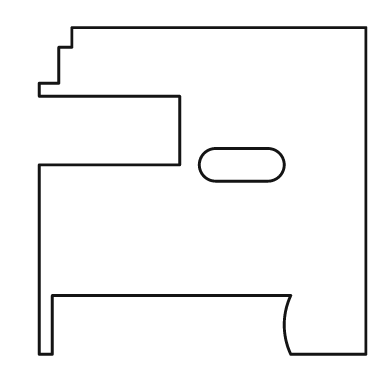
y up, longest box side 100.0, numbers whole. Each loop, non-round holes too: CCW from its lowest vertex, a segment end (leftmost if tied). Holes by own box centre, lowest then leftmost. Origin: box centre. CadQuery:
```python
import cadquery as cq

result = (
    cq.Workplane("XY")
    .moveTo(-50.0, -50.0)
    .lineTo(-46.0, -50.0)
    .lineTo(-46.0, -32.0)
    .lineTo(27.0, -32.0)
    .threePointArc((25.0, -41.0), (27.0, -50.0))
    .lineTo(50.0, -50.0)
    .lineTo(50.0, 50.0)
    .lineTo(-40.0, 50.0)
    .lineTo(-40.0, 44.0)
    .lineTo(-44.0, 44.0)
    .lineTo(-44.0, 33.0)
    .lineTo(-50.0, 33.0)
    .lineTo(-50.0, 29.0)
    .lineTo(-7.0, 29.0)
    .lineTo(-7.0, 8.0)
    .lineTo(-50.0, 8.0)
    .close()
    .moveTo(4.0, 3.0)
    .lineTo(20.0, 3.0)
    .threePointArc((25.0, 8.0), (20.0, 13.0))
    .lineTo(4.0, 13.0)
    .threePointArc((-1.0, 8.0), (4.0, 3.0))
    .close()
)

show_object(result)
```